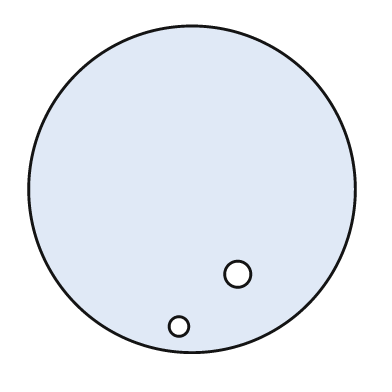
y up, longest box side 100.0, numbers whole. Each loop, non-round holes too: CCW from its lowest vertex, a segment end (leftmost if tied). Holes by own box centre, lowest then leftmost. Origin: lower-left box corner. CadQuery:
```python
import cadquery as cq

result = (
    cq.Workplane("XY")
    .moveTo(50.0, 50.0)
    .circle(50.0)
    .moveTo(46.0, 8.0)
    .circle(3.0)
    .moveTo(64.0, 24.0)
    .circle(4.0)
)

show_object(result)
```